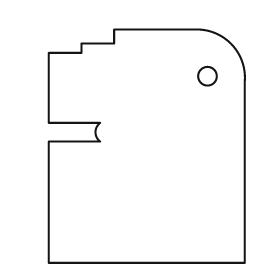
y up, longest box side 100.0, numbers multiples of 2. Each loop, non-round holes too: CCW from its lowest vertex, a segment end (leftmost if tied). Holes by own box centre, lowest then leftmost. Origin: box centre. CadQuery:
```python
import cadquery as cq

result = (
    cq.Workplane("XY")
    .moveTo(-42.0, -50.0)
    .lineTo(42.0, -50.0)
    .lineTo(42.0, 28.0)
    .threePointArc((36.0, 44.0), (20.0, 50.0))
    .lineTo(-14.0, 50.0)
    .lineTo(-14.0, 44.0)
    .lineTo(-28.0, 44.0)
    .lineTo(-28.0, 40.0)
    .lineTo(-42.0, 40.0)
    .lineTo(-42.0, 10.0)
    .lineTo(-20.0, 10.0)
    .threePointArc((-22.0, 6.0), (-20.0, 2.0))
    .lineTo(-42.0, 2.0)
    .close()
    .moveTo(26.0, 30.0)
    .circle(4.0)
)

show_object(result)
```